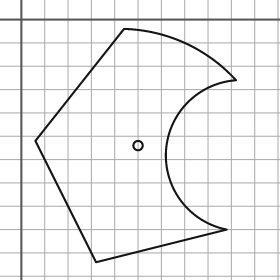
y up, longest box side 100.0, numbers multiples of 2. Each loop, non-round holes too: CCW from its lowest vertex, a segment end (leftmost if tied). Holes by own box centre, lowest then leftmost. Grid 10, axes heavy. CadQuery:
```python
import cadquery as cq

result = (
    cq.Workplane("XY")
    .moveTo(32.0, -104.0)
    .lineTo(88.0, -90.0)
    .threePointArc((62.0, -56.0), (92.0, -26.0))
    .threePointArc((70.0, -10.0), (44.0, -4.0))
    .lineTo(6.0, -52.0)
    .close()
    .moveTo(50.0, -54.0)
    .circle(2.0)
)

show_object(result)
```